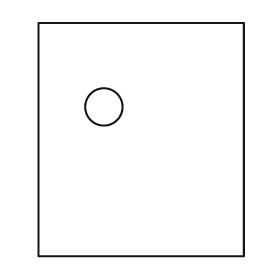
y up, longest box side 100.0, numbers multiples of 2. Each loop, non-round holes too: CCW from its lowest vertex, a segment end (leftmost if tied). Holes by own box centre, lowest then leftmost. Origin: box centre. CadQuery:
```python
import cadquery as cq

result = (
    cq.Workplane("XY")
    .moveTo(-44.0, -50.0)
    .lineTo(44.0, -50.0)
    .lineTo(44.0, 50.0)
    .lineTo(-44.0, 50.0)
    .close()
    .moveTo(-16.0, 14.0)
    .circle(8.0)
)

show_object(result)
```